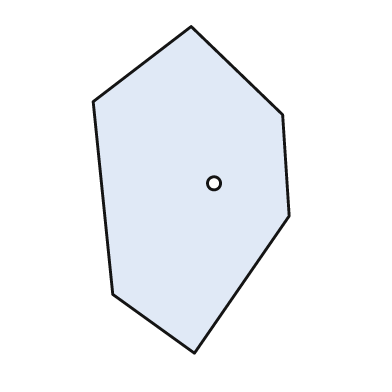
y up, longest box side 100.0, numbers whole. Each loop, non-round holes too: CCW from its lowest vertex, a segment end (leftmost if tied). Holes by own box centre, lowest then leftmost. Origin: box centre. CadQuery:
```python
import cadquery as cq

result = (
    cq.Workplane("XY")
    .moveTo(1.0, -50.0)
    .lineTo(30.0, -8.0)
    .lineTo(28.0, 23.0)
    .lineTo(0.0, 50.0)
    .lineTo(-30.0, 27.0)
    .lineTo(-24.0, -32.0)
    .close()
    .moveTo(7.0, 2.0)
    .circle(2.0)
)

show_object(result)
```